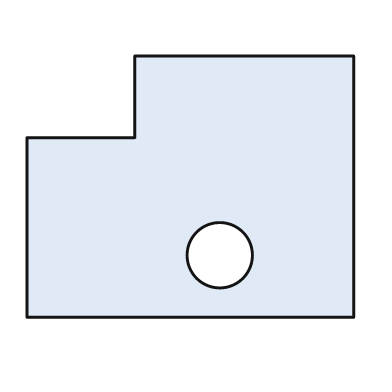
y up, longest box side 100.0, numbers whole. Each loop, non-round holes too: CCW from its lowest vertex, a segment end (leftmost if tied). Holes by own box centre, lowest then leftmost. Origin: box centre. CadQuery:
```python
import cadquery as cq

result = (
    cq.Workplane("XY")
    .moveTo(-50.0, -40.0)
    .lineTo(50.0, -40.0)
    .lineTo(50.0, 40.0)
    .lineTo(-17.0, 40.0)
    .lineTo(-17.0, 15.0)
    .lineTo(-50.0, 15.0)
    .close()
    .moveTo(9.0, -21.0)
    .circle(10.0)
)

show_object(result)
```